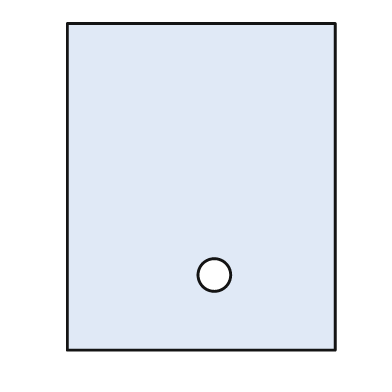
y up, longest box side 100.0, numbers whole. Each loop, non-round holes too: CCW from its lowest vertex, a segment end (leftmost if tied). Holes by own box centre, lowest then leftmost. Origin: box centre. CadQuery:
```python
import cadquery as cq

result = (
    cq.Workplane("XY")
    .moveTo(-41.0, -50.0)
    .lineTo(41.0, -50.0)
    .lineTo(41.0, 50.0)
    .lineTo(-41.0, 50.0)
    .close()
    .moveTo(4.0, -27.0)
    .circle(5.0)
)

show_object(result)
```